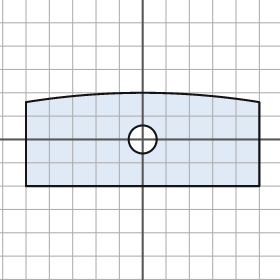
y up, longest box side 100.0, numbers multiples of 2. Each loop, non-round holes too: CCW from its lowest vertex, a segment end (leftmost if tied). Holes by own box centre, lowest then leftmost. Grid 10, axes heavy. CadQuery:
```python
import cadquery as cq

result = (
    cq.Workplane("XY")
    .moveTo(-50.0, -20.0)
    .lineTo(50.0, -20.0)
    .lineTo(50.0, 16.0)
    .threePointArc((0.0, 20.0), (-50.0, 16.0))
    .close()
    .moveTo(0.0, 0.0)
    .circle(6.0)
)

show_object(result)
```